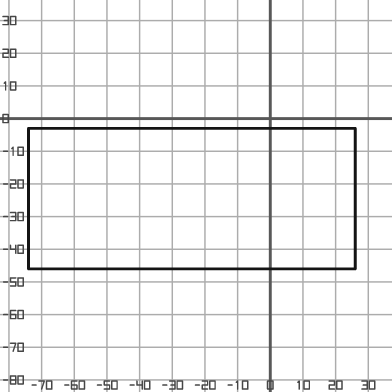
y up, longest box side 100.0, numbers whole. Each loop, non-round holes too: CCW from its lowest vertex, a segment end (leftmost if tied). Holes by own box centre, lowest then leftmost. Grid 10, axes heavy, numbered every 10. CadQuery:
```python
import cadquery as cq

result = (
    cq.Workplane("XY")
    .moveTo(-74.0, -46.0)
    .lineTo(26.0, -46.0)
    .lineTo(26.0, -3.0)
    .lineTo(-74.0, -3.0)
    .close()
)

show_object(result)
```